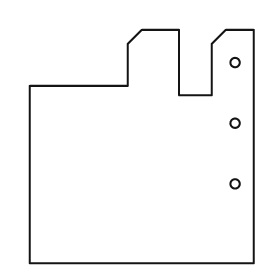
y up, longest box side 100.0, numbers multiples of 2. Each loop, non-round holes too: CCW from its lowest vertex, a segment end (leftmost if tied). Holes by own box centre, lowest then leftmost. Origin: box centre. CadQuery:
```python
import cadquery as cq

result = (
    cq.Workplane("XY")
    .moveTo(-48.0, -50.0)
    .lineTo(48.0, -50.0)
    .lineTo(48.0, 50.0)
    .lineTo(36.0, 50.0)
    .lineTo(30.0, 44.0)
    .lineTo(30.0, 22.0)
    .lineTo(16.0, 22.0)
    .lineTo(16.0, 50.0)
    .lineTo(0.0, 50.0)
    .lineTo(-6.0, 44.0)
    .lineTo(-6.0, 26.0)
    .lineTo(-48.0, 26.0)
    .close()
    .moveTo(40.0, -16.0)
    .circle(2.0)
    .moveTo(40.0, 10.0)
    .circle(2.0)
    .moveTo(40.0, 36.0)
    .circle(2.0)
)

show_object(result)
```